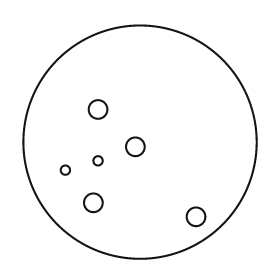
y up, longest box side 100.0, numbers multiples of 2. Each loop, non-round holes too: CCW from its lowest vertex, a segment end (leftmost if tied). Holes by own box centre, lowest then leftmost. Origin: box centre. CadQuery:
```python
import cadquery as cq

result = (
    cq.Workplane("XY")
    .moveTo(0.0, 0.0)
    .circle(50.0)
    .moveTo(24.0, -32.0)
    .circle(4.0)
    .moveTo(-20.0, -26.0)
    .circle(4.0)
    .moveTo(-32.0, -12.0)
    .circle(2.0)
    .moveTo(-18.0, -8.0)
    .circle(2.0)
    .moveTo(-2.0, -2.0)
    .circle(4.0)
    .moveTo(-18.0, 14.0)
    .circle(4.0)
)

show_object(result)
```